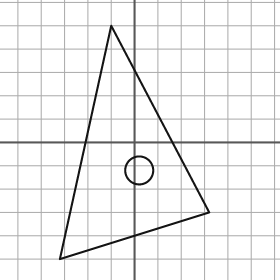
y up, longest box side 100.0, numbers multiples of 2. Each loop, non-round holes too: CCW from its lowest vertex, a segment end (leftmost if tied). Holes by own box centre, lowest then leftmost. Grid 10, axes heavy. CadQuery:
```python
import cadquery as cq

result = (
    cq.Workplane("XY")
    .moveTo(-32.0, -50.0)
    .lineTo(32.0, -30.0)
    .lineTo(-10.0, 50.0)
    .close()
    .moveTo(2.0, -12.0)
    .circle(6.0)
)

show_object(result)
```